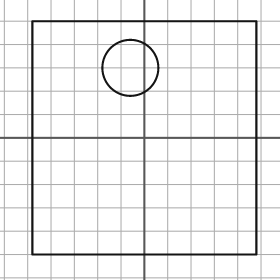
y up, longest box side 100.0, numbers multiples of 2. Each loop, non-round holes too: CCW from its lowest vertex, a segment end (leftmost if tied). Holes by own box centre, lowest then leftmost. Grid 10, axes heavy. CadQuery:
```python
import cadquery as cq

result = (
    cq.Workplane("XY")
    .moveTo(-48.0, -50.0)
    .lineTo(48.0, -50.0)
    .lineTo(48.0, 50.0)
    .lineTo(-48.0, 50.0)
    .close()
    .moveTo(-6.0, 30.0)
    .circle(12.0)
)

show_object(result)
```